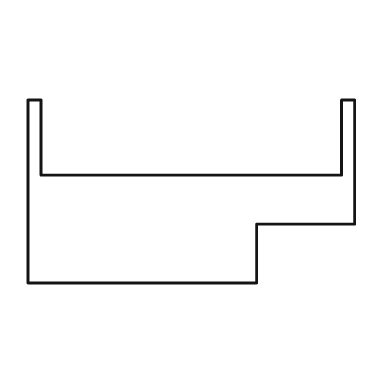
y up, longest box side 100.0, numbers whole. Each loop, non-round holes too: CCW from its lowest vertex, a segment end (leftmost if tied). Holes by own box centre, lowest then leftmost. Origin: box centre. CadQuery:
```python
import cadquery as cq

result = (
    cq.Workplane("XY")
    .moveTo(-50.0, -28.0)
    .lineTo(20.0, -28.0)
    .lineTo(20.0, -10.0)
    .lineTo(50.0, -10.0)
    .lineTo(50.0, 28.0)
    .lineTo(46.0, 28.0)
    .lineTo(46.0, 5.0)
    .lineTo(-46.0, 5.0)
    .lineTo(-46.0, 28.0)
    .lineTo(-50.0, 28.0)
    .close()
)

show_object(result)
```